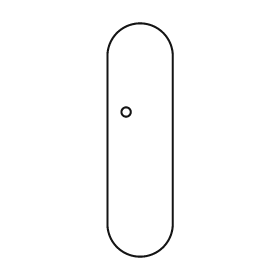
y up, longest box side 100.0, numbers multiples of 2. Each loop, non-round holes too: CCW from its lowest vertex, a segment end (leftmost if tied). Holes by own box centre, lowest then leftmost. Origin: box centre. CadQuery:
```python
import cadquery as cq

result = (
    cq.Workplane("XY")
    .moveTo(-14.0, -36.0)
    .threePointArc((0.0, -50.0), (14.0, -36.0))
    .lineTo(14.0, 36.0)
    .threePointArc((0.0, 50.0), (-14.0, 36.0))
    .close()
    .moveTo(-6.0, 12.0)
    .circle(2.0)
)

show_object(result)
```